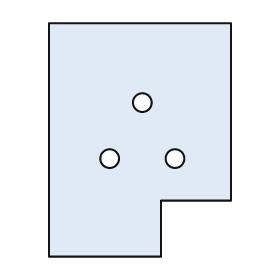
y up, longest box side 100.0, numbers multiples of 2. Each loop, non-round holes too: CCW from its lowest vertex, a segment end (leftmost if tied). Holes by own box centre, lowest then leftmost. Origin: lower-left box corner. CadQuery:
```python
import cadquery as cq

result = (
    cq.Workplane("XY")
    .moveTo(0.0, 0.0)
    .lineTo(48.0, 0.0)
    .lineTo(48.0, 24.0)
    .lineTo(78.0, 24.0)
    .lineTo(78.0, 100.0)
    .lineTo(0.0, 100.0)
    .close()
    .moveTo(26.0, 42.0)
    .circle(4.0)
    .moveTo(54.0, 42.0)
    .circle(4.0)
    .moveTo(40.0, 66.0)
    .circle(4.0)
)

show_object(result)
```